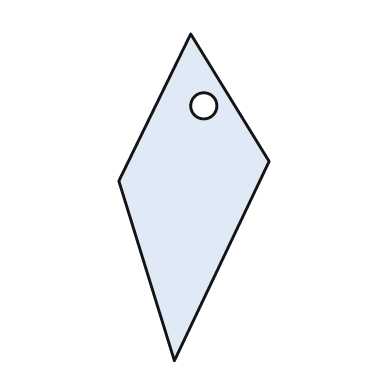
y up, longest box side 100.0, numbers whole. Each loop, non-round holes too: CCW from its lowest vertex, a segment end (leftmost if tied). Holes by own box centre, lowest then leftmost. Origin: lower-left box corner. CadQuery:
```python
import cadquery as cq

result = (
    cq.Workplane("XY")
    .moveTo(17.0, 0.0)
    .lineTo(46.0, 61.0)
    .lineTo(22.0, 100.0)
    .lineTo(0.0, 55.0)
    .close()
    .moveTo(26.0, 78.0)
    .circle(4.0)
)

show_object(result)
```